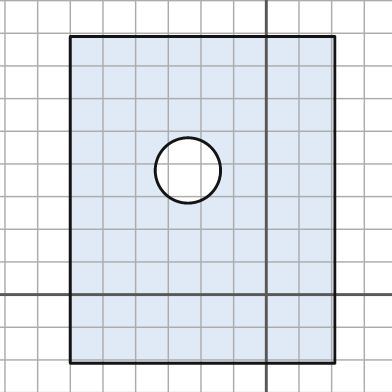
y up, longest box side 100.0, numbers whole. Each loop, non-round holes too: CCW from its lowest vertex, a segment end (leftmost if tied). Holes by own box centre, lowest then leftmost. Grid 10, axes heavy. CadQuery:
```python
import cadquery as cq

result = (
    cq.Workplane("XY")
    .moveTo(-60.0, -21.0)
    .lineTo(21.0, -21.0)
    .lineTo(21.0, 79.0)
    .lineTo(-60.0, 79.0)
    .close()
    .moveTo(-24.0, 38.0)
    .circle(10.0)
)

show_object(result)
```